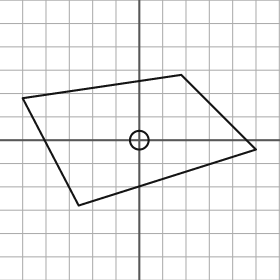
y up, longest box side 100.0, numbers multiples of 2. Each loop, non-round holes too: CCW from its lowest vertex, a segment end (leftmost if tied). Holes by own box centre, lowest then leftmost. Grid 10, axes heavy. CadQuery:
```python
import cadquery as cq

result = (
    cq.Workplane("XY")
    .moveTo(-26.0, -28.0)
    .lineTo(50.0, -4.0)
    .lineTo(18.0, 28.0)
    .lineTo(-50.0, 18.0)
    .close()
    .moveTo(0.0, 0.0)
    .circle(4.0)
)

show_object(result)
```